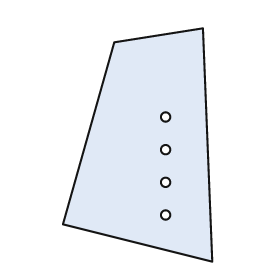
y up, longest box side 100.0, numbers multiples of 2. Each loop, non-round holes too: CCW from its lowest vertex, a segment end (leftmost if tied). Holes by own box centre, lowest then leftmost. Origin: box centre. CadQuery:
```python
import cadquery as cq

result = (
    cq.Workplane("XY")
    .moveTo(32.0, -50.0)
    .lineTo(28.0, 50.0)
    .lineTo(-10.0, 44.0)
    .lineTo(-32.0, -34.0)
    .close()
    .moveTo(12.0, -30.0)
    .circle(2.0)
    .moveTo(12.0, -16.0)
    .circle(2.0)
    .moveTo(12.0, -2.0)
    .circle(2.0)
    .moveTo(12.0, 12.0)
    .circle(2.0)
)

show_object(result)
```